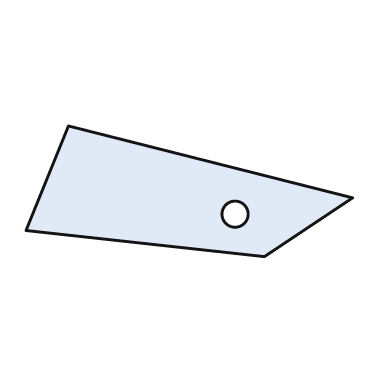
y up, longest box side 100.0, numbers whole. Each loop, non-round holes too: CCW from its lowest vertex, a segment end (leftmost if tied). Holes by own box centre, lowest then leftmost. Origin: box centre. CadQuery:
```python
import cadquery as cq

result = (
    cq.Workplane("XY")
    .moveTo(23.0, -20.0)
    .lineTo(50.0, -2.0)
    .lineTo(-37.0, 20.0)
    .lineTo(-50.0, -12.0)
    .close()
    .moveTo(14.0, -7.0)
    .circle(4.0)
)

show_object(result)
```